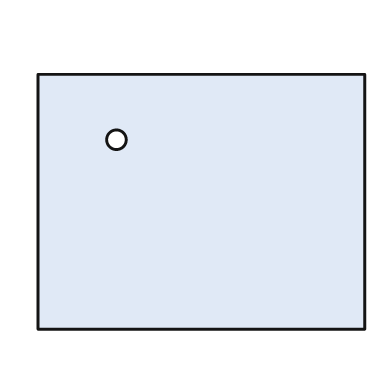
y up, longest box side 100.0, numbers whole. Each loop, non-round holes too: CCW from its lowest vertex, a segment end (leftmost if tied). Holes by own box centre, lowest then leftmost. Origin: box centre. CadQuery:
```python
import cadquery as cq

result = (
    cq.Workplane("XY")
    .moveTo(-50.0, -39.0)
    .lineTo(50.0, -39.0)
    .lineTo(50.0, 39.0)
    .lineTo(-50.0, 39.0)
    .close()
    .moveTo(-26.0, 19.0)
    .circle(3.0)
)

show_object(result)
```